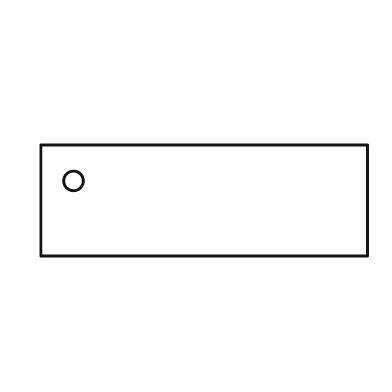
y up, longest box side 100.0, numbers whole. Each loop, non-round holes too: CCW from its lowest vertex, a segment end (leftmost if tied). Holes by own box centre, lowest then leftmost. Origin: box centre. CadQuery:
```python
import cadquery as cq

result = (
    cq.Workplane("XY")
    .moveTo(-50.0, -17.0)
    .lineTo(50.0, -17.0)
    .lineTo(50.0, 17.0)
    .lineTo(-50.0, 17.0)
    .close()
    .moveTo(-40.0, 6.0)
    .circle(3.0)
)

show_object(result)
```